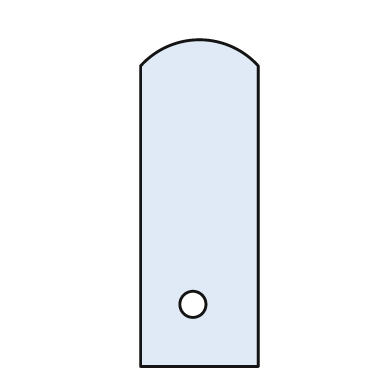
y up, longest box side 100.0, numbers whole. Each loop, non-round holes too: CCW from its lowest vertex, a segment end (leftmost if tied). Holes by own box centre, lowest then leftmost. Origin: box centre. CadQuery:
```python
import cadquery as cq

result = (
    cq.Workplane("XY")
    .moveTo(-18.0, -50.0)
    .lineTo(18.0, -50.0)
    .lineTo(18.0, 42.0)
    .threePointArc((0.0, 50.0), (-18.0, 42.0))
    .close()
    .moveTo(-2.0, -31.0)
    .circle(4.0)
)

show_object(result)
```